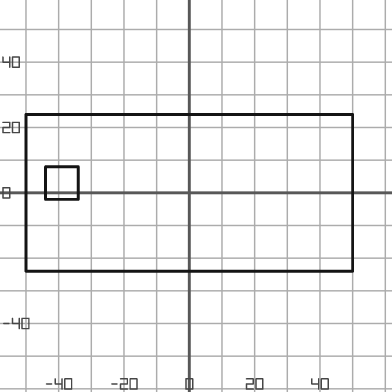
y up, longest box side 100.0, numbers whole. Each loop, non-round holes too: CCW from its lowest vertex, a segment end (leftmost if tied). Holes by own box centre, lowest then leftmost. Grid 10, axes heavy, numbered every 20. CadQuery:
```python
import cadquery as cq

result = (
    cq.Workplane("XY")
    .moveTo(-50.0, -24.0)
    .lineTo(50.0, -24.0)
    .lineTo(50.0, 24.0)
    .lineTo(-50.0, 24.0)
    .close()
    .moveTo(-44.0, -2.0)
    .lineTo(-34.0, -2.0)
    .lineTo(-34.0, 8.0)
    .lineTo(-44.0, 8.0)
    .close()
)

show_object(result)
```